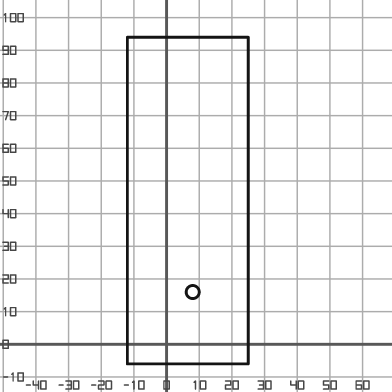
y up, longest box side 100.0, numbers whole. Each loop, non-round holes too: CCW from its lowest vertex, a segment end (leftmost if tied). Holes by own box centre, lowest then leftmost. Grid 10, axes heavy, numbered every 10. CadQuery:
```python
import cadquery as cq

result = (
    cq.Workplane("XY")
    .moveTo(-12.0, -6.0)
    .lineTo(25.0, -6.0)
    .lineTo(25.0, 94.0)
    .lineTo(-12.0, 94.0)
    .close()
    .moveTo(8.0, 16.0)
    .circle(2.0)
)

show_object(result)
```